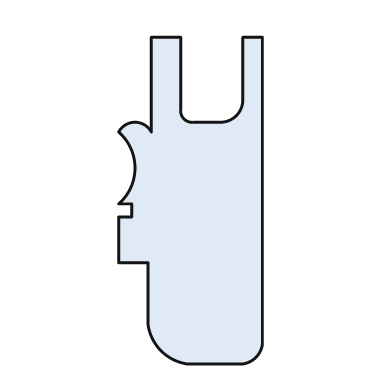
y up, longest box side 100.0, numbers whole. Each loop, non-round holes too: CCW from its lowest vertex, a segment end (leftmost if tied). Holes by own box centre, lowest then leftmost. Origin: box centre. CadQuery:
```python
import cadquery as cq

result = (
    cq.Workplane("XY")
    .moveTo(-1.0, -50.0)
    .lineTo(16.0, -50.0)
    .threePointArc((20.0, -48.0), (22.0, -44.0))
    .lineTo(22.0, 50.0)
    .lineTo(16.0, 50.0)
    .lineTo(16.0, 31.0)
    .threePointArc((14.0, 26.0), (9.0, 24.0))
    .lineTo(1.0, 24.0)
    .threePointArc((-2.0, 25.0), (-3.0, 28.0))
    .lineTo(-3.0, 50.0)
    .lineTo(-12.0, 50.0)
    .lineTo(-12.0, 21.0)
    .threePointArc((-17.0, 24.0), (-22.0, 21.0))
    .threePointArc((-17.0, 10.0), (-22.0, -1.0))
    .lineTo(-18.0, -1.0)
    .lineTo(-18.0, -5.0)
    .lineTo(-22.0, -5.0)
    .lineTo(-22.0, -19.0)
    .lineTo(-13.0, -19.0)
    .lineTo(-13.0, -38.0)
    .threePointArc((-9.0, -46.0), (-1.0, -50.0))
    .close()
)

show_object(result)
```